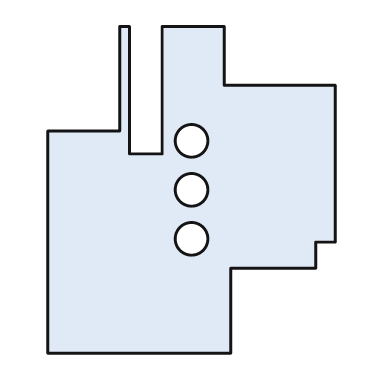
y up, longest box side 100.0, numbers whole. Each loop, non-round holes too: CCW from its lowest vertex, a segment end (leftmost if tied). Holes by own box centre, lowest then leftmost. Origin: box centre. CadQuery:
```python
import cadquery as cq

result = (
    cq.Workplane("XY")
    .moveTo(-44.0, -50.0)
    .lineTo(12.0, -50.0)
    .lineTo(12.0, -24.0)
    .lineTo(38.0, -24.0)
    .lineTo(38.0, -16.0)
    .lineTo(44.0, -16.0)
    .lineTo(44.0, 32.0)
    .lineTo(10.0, 32.0)
    .lineTo(10.0, 50.0)
    .lineTo(-9.0, 50.0)
    .lineTo(-9.0, 11.0)
    .lineTo(-19.0, 11.0)
    .lineTo(-19.0, 50.0)
    .lineTo(-22.0, 50.0)
    .lineTo(-22.0, 18.0)
    .lineTo(-44.0, 18.0)
    .close()
    .moveTo(0.0, -15.0)
    .circle(5.0)
    .moveTo(0.0, 0.0)
    .circle(5.0)
    .moveTo(0.0, 15.0)
    .circle(5.0)
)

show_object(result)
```